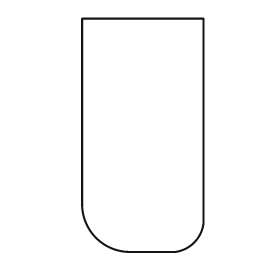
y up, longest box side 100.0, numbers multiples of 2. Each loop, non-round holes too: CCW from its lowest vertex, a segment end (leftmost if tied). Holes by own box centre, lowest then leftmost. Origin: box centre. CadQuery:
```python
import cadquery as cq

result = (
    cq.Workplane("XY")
    .moveTo(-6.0, -50.0)
    .lineTo(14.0, -50.0)
    .threePointArc((22.0, -46.0), (26.0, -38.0))
    .lineTo(26.0, 50.0)
    .lineTo(-26.0, 50.0)
    .lineTo(-26.0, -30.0)
    .threePointArc((-20.0, -44.0), (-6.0, -50.0))
    .close()
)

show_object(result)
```